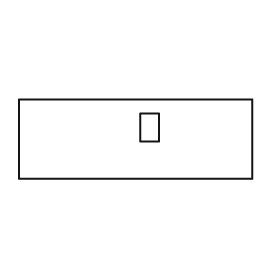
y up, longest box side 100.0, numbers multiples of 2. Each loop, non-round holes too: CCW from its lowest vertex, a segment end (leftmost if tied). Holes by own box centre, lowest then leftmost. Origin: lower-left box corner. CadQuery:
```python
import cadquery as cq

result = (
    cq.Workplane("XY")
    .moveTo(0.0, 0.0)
    .lineTo(100.0, 0.0)
    .lineTo(100.0, 34.0)
    .lineTo(0.0, 34.0)
    .close()
    .moveTo(52.0, 16.0)
    .lineTo(60.0, 16.0)
    .lineTo(60.0, 28.0)
    .lineTo(52.0, 28.0)
    .close()
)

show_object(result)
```